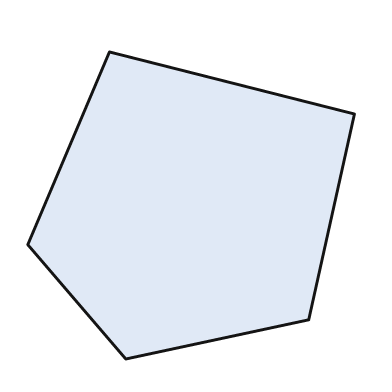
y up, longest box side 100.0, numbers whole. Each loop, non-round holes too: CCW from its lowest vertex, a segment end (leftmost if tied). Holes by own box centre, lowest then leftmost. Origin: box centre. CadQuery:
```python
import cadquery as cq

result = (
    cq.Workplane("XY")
    .moveTo(-20.0, -47.0)
    .lineTo(36.0, -35.0)
    .lineTo(50.0, 28.0)
    .lineTo(-25.0, 47.0)
    .lineTo(-50.0, -12.0)
    .close()
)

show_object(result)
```